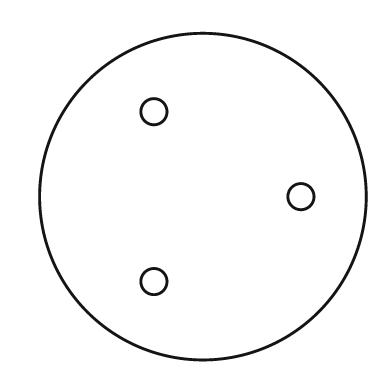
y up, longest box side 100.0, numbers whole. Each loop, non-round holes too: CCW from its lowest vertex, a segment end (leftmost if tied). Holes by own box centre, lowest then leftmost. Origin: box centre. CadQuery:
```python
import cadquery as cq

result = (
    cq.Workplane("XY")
    .moveTo(0.0, 0.0)
    .circle(50.0)
    .moveTo(-15.0, -26.0)
    .circle(4.0)
    .moveTo(30.0, 0.0)
    .circle(4.0)
    .moveTo(-15.0, 26.0)
    .circle(4.0)
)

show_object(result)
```